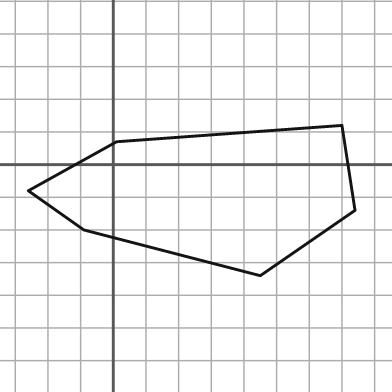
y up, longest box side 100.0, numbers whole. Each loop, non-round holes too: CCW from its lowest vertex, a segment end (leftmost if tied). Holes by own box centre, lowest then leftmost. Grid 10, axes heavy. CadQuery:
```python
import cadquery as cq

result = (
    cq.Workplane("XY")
    .moveTo(45.0, -34.0)
    .lineTo(74.0, -14.0)
    .lineTo(70.0, 12.0)
    .lineTo(1.0, 7.0)
    .lineTo(-26.0, -8.0)
    .lineTo(-9.0, -20.0)
    .close()
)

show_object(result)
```